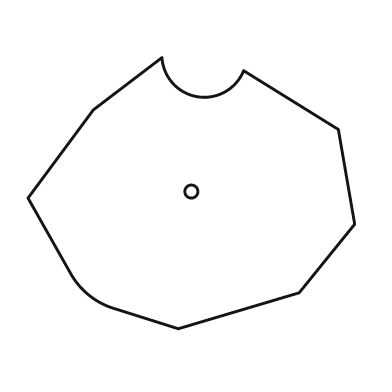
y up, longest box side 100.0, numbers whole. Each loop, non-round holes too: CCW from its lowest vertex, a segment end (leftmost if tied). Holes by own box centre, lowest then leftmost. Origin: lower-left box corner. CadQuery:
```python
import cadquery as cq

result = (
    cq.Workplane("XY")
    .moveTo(46.0, 0.0)
    .lineTo(83.0, 11.0)
    .lineTo(100.0, 32.0)
    .lineTo(95.0, 61.0)
    .lineTo(66.0, 79.0)
    .threePointArc((52.0, 71.0), (41.0, 83.0))
    .lineTo(20.0, 67.0)
    .lineTo(0.0, 40.0)
    .lineTo(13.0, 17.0)
    .threePointArc((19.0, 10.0), (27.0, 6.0))
    .close()
    .moveTo(50.0, 42.0)
    .circle(2.0)
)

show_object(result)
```